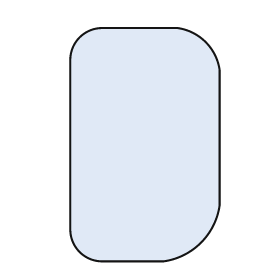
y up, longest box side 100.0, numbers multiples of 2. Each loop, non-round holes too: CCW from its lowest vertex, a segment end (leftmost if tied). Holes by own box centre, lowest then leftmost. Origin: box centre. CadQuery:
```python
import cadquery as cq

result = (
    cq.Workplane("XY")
    .moveTo(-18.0, -50.0)
    .lineTo(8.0, -50.0)
    .threePointArc((24.0, -42.0), (32.0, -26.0))
    .lineTo(32.0, 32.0)
    .threePointArc((26.0, 44.0), (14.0, 50.0))
    .lineTo(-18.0, 50.0)
    .threePointArc((-28.0, 46.0), (-32.0, 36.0))
    .lineTo(-32.0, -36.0)
    .threePointArc((-28.0, -46.0), (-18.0, -50.0))
    .close()
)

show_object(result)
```